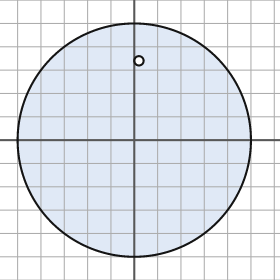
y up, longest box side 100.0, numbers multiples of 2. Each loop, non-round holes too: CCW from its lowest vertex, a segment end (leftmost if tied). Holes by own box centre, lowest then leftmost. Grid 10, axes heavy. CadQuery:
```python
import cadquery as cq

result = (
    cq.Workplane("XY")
    .moveTo(0.0, 0.0)
    .circle(50.0)
    .moveTo(2.0, 34.0)
    .circle(2.0)
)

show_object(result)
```